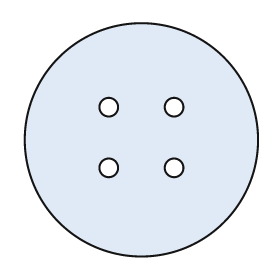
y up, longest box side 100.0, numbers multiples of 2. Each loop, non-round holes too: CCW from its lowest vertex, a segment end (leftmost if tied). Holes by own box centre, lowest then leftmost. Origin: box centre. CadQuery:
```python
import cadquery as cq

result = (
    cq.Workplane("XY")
    .moveTo(0.0, 0.0)
    .circle(50.0)
    .moveTo(-14.0, -12.0)
    .circle(4.0)
    .moveTo(14.0, -12.0)
    .circle(4.0)
    .moveTo(-14.0, 14.0)
    .circle(4.0)
    .moveTo(14.0, 14.0)
    .circle(4.0)
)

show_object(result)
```